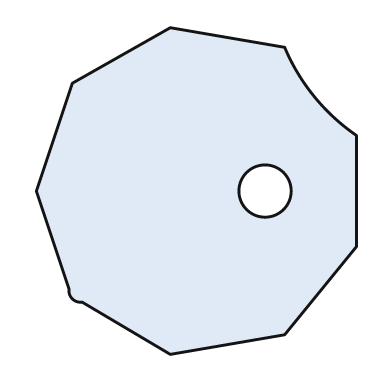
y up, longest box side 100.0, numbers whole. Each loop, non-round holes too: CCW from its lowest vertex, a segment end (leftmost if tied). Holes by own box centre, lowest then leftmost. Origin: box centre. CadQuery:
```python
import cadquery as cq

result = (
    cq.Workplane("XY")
    .moveTo(-8.0, -50.0)
    .lineTo(27.0, -44.0)
    .lineTo(49.0, -17.0)
    .lineTo(49.0, 17.0)
    .threePointArc((36.0, 29.0), (27.0, 44.0))
    .lineTo(-8.0, 50.0)
    .lineTo(-38.0, 33.0)
    .lineTo(-49.0, 0.0)
    .lineTo(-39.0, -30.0)
    .threePointArc((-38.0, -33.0), (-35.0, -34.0))
    .close()
    .moveTo(21.0, 0.0)
    .circle(8.0)
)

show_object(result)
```